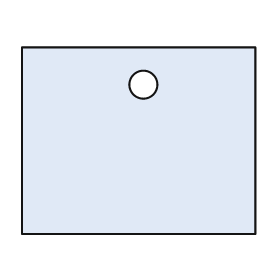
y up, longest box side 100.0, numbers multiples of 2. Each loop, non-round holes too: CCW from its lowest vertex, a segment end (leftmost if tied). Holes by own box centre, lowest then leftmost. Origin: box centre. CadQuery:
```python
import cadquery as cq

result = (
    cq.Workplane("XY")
    .moveTo(-50.0, -40.0)
    .lineTo(50.0, -40.0)
    .lineTo(50.0, 40.0)
    .lineTo(-50.0, 40.0)
    .close()
    .moveTo(2.0, 24.0)
    .circle(6.0)
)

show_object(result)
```